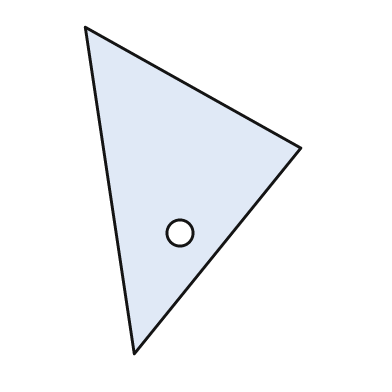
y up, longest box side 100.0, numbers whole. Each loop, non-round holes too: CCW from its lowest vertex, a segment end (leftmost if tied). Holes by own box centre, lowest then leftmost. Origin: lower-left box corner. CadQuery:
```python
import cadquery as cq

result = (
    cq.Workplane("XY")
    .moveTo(15.0, 0.0)
    .lineTo(66.0, 63.0)
    .lineTo(0.0, 100.0)
    .close()
    .moveTo(29.0, 37.0)
    .circle(4.0)
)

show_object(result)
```